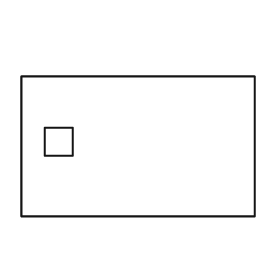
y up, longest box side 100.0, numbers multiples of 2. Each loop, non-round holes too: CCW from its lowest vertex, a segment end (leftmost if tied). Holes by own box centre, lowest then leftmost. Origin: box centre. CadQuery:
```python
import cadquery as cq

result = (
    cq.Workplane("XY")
    .moveTo(-50.0, -30.0)
    .lineTo(50.0, -30.0)
    .lineTo(50.0, 30.0)
    .lineTo(-50.0, 30.0)
    .close()
    .moveTo(-40.0, -4.0)
    .lineTo(-28.0, -4.0)
    .lineTo(-28.0, 8.0)
    .lineTo(-40.0, 8.0)
    .close()
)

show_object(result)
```